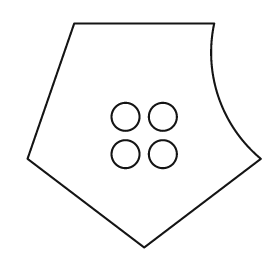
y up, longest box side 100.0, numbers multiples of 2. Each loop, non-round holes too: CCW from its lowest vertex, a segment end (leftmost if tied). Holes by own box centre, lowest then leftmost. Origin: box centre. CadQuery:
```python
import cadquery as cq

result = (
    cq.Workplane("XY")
    .moveTo(0.0, -48.0)
    .lineTo(50.0, -10.0)
    .threePointArc((32.0, 16.0), (30.0, 48.0))
    .lineTo(-30.0, 48.0)
    .lineTo(-50.0, -10.0)
    .close()
    .moveTo(-8.0, -8.0)
    .circle(6.0)
    .moveTo(8.0, -8.0)
    .circle(6.0)
    .moveTo(-8.0, 8.0)
    .circle(6.0)
    .moveTo(8.0, 8.0)
    .circle(6.0)
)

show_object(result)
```